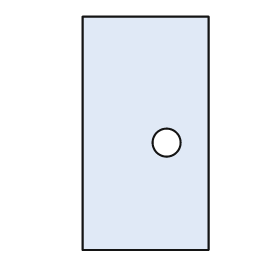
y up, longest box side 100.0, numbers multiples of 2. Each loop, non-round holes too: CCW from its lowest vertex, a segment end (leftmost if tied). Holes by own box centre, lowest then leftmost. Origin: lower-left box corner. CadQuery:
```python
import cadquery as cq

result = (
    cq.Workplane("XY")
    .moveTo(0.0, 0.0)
    .lineTo(54.0, 0.0)
    .lineTo(54.0, 100.0)
    .lineTo(0.0, 100.0)
    .close()
    .moveTo(36.0, 46.0)
    .circle(6.0)
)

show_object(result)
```